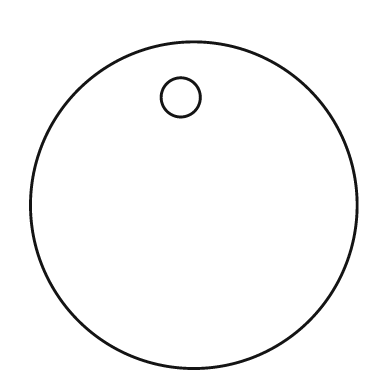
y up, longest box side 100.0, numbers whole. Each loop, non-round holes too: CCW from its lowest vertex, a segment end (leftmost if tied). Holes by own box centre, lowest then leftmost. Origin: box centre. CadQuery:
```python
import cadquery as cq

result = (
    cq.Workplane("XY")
    .moveTo(0.0, 0.0)
    .circle(50.0)
    .moveTo(-4.0, 33.0)
    .circle(6.0)
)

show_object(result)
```